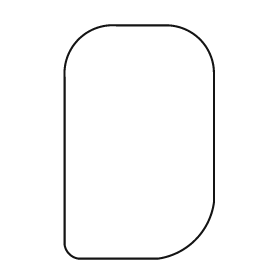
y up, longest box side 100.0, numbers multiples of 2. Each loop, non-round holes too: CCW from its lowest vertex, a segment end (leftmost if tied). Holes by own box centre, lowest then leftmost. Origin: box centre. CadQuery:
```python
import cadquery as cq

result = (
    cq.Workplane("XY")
    .moveTo(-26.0, -50.0)
    .lineTo(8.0, -50.0)
    .threePointArc((24.0, -42.0), (32.0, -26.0))
    .lineTo(32.0, 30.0)
    .threePointArc((26.0, 44.0), (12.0, 50.0))
    .lineTo(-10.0, 50.0)
    .threePointArc((-26.0, 44.0), (-32.0, 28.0))
    .lineTo(-32.0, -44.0)
    .threePointArc((-30.0, -48.0), (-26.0, -50.0))
    .close()
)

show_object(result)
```